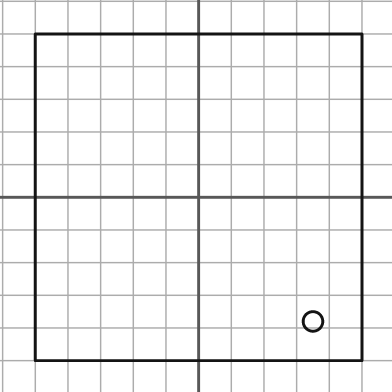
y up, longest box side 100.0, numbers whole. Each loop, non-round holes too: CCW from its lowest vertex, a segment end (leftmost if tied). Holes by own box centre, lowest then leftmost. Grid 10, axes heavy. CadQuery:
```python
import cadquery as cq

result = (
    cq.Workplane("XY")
    .moveTo(-50.0, -50.0)
    .lineTo(50.0, -50.0)
    .lineTo(50.0, 50.0)
    .lineTo(-50.0, 50.0)
    .close()
    .moveTo(35.0, -38.0)
    .circle(3.0)
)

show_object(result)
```